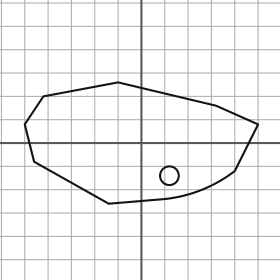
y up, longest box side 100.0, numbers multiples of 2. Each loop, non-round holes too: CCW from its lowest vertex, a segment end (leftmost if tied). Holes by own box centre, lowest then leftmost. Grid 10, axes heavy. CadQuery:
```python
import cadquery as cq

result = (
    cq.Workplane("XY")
    .moveTo(-14.0, -26.0)
    .lineTo(10.0, -24.0)
    .threePointArc((26.0, -20.0), (40.0, -12.0))
    .lineTo(50.0, 8.0)
    .lineTo(32.0, 16.0)
    .lineTo(-10.0, 26.0)
    .lineTo(-42.0, 20.0)
    .lineTo(-50.0, 8.0)
    .lineTo(-46.0, -8.0)
    .close()
    .moveTo(12.0, -14.0)
    .circle(4.0)
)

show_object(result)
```